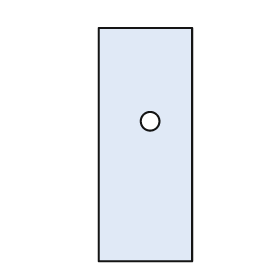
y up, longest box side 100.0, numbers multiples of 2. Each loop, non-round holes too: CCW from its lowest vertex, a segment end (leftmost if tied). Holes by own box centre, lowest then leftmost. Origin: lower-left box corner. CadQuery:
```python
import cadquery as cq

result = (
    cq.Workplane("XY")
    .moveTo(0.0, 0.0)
    .lineTo(40.0, 0.0)
    .lineTo(40.0, 100.0)
    .lineTo(0.0, 100.0)
    .close()
    .moveTo(22.0, 60.0)
    .circle(4.0)
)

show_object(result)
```